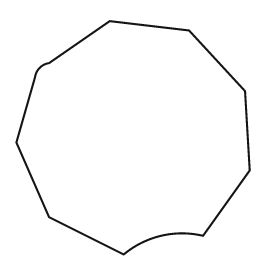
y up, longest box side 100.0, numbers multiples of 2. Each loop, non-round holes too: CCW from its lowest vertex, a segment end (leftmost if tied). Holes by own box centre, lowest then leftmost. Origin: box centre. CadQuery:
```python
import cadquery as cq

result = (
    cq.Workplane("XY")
    .moveTo(-4.0, -50.0)
    .threePointArc((12.0, -42.0), (30.0, -42.0))
    .lineTo(50.0, -14.0)
    .lineTo(48.0, 20.0)
    .lineTo(24.0, 46.0)
    .lineTo(-10.0, 50.0)
    .lineTo(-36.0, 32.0)
    .threePointArc((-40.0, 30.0), (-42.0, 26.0))
    .lineTo(-50.0, -2.0)
    .lineTo(-36.0, -34.0)
    .close()
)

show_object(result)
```